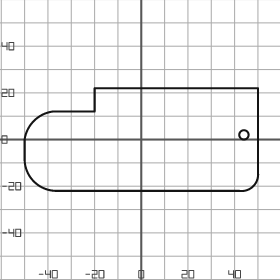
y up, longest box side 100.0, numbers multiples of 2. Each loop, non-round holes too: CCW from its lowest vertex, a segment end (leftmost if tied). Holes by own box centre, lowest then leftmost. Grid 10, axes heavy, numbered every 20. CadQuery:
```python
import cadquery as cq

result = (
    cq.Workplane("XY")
    .moveTo(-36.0, -22.0)
    .lineTo(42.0, -22.0)
    .threePointArc((48.0, -20.0), (50.0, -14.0))
    .lineTo(50.0, 22.0)
    .lineTo(-20.0, 22.0)
    .lineTo(-20.0, 12.0)
    .lineTo(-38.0, 12.0)
    .threePointArc((-46.0, 8.0), (-50.0, 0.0))
    .lineTo(-50.0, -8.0)
    .threePointArc((-46.0, -18.0), (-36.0, -22.0))
    .close()
    .moveTo(44.0, 2.0)
    .circle(2.0)
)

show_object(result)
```